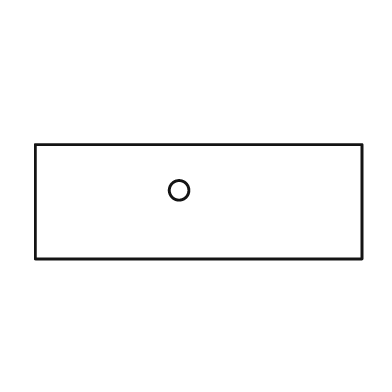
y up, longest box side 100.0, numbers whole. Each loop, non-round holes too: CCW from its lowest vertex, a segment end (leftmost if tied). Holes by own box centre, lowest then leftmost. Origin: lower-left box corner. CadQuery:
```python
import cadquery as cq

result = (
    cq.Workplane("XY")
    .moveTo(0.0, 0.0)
    .lineTo(100.0, 0.0)
    .lineTo(100.0, 35.0)
    .lineTo(0.0, 35.0)
    .close()
    .moveTo(44.0, 21.0)
    .circle(3.0)
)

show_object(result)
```